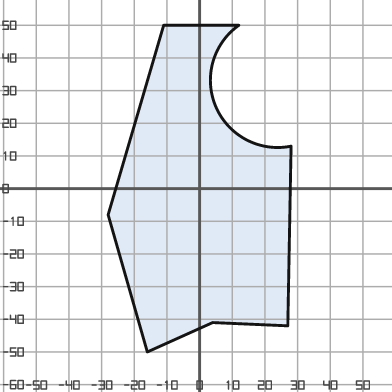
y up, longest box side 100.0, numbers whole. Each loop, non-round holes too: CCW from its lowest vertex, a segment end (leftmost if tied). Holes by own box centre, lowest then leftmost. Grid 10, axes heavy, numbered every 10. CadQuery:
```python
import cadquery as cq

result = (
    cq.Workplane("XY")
    .moveTo(-16.0, -50.0)
    .lineTo(4.0, -41.0)
    .lineTo(27.0, -42.0)
    .lineTo(28.0, 13.0)
    .threePointArc((5.0, 25.0), (12.0, 50.0))
    .lineTo(-11.0, 50.0)
    .lineTo(-28.0, -8.0)
    .close()
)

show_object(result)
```